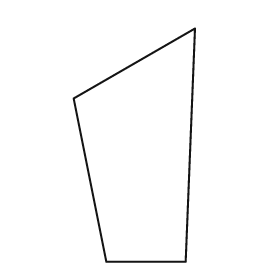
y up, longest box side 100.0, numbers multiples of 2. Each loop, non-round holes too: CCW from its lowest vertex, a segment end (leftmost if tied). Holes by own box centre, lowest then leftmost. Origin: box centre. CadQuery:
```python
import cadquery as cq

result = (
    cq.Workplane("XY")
    .moveTo(-12.0, -50.0)
    .lineTo(22.0, -50.0)
    .lineTo(26.0, 50.0)
    .lineTo(-26.0, 20.0)
    .close()
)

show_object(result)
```